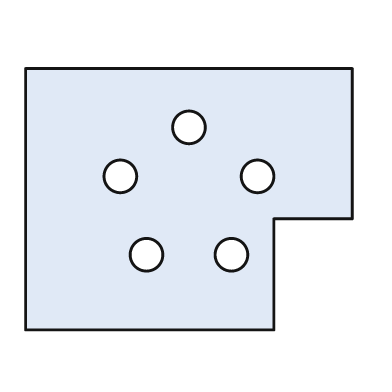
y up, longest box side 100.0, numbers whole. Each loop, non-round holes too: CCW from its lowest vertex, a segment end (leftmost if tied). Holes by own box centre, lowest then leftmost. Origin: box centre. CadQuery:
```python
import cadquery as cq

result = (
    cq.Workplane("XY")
    .moveTo(-50.0, -40.0)
    .lineTo(26.0, -40.0)
    .lineTo(26.0, -6.0)
    .lineTo(50.0, -6.0)
    .lineTo(50.0, 40.0)
    .lineTo(-50.0, 40.0)
    .close()
    .moveTo(-13.0, -17.0)
    .circle(5.0)
    .moveTo(13.0, -17.0)
    .circle(5.0)
    .moveTo(-21.0, 7.0)
    .circle(5.0)
    .moveTo(21.0, 7.0)
    .circle(5.0)
    .moveTo(0.0, 22.0)
    .circle(5.0)
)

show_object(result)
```